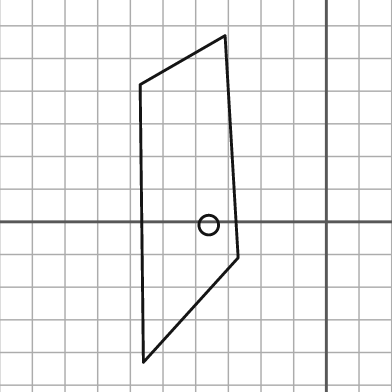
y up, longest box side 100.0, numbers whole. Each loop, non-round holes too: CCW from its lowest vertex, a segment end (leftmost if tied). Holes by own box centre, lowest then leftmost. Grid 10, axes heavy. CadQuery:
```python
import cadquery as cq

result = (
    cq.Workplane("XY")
    .moveTo(-56.0, -43.0)
    .lineTo(-27.0, -11.0)
    .lineTo(-31.0, 57.0)
    .lineTo(-57.0, 42.0)
    .close()
    .moveTo(-36.0, -1.0)
    .circle(3.0)
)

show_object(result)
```